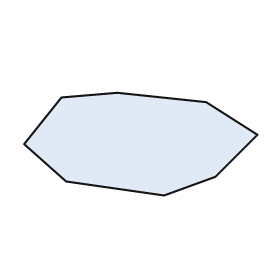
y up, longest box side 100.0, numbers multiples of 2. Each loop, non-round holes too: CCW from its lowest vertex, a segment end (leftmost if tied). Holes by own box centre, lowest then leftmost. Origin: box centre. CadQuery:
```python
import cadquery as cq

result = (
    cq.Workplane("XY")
    .moveTo(10.0, -22.0)
    .lineTo(32.0, -14.0)
    .lineTo(50.0, 4.0)
    .lineTo(28.0, 18.0)
    .lineTo(-10.0, 22.0)
    .lineTo(-34.0, 20.0)
    .lineTo(-50.0, 0.0)
    .lineTo(-32.0, -16.0)
    .close()
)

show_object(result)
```